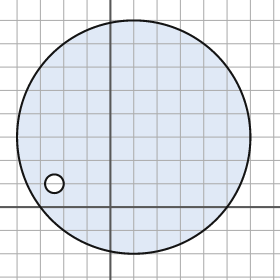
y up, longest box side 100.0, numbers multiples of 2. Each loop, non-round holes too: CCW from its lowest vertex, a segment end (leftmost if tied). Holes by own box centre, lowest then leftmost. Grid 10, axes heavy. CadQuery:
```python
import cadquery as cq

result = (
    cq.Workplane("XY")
    .moveTo(10.0, 30.0)
    .circle(50.0)
    .moveTo(-24.0, 10.0)
    .circle(4.0)
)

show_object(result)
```